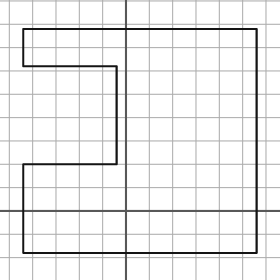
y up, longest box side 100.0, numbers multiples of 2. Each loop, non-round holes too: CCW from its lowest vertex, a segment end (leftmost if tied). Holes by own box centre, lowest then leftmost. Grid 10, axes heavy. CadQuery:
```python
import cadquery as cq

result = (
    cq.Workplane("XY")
    .moveTo(-44.0, -18.0)
    .lineTo(56.0, -18.0)
    .lineTo(56.0, 78.0)
    .lineTo(-44.0, 78.0)
    .lineTo(-44.0, 62.0)
    .lineTo(-4.0, 62.0)
    .lineTo(-4.0, 20.0)
    .lineTo(-44.0, 20.0)
    .close()
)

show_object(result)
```